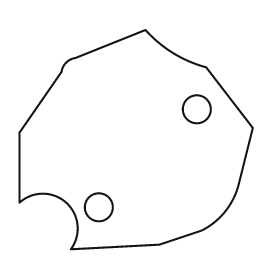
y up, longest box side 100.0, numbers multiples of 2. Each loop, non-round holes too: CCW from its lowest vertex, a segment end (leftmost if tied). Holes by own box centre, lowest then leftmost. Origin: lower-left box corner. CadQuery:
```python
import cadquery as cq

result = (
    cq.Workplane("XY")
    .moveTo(22.0, 0.0)
    .lineTo(60.0, 2.0)
    .lineTo(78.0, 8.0)
    .threePointArc((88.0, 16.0), (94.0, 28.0))
    .lineTo(100.0, 52.0)
    .lineTo(80.0, 78.0)
    .threePointArc((66.0, 84.0), (54.0, 94.0))
    .lineTo(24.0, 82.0)
    .threePointArc((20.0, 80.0), (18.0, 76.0))
    .lineTo(0.0, 50.0)
    .lineTo(0.0, 20.0)
    .threePointArc((20.0, 20.0), (22.0, 0.0))
    .close()
    .moveTo(34.0, 18.0)
    .circle(6.0)
    .moveTo(76.0, 60.0)
    .circle(6.0)
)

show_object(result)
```